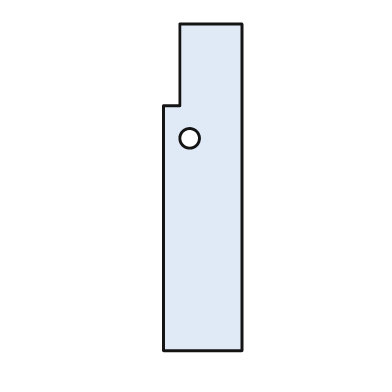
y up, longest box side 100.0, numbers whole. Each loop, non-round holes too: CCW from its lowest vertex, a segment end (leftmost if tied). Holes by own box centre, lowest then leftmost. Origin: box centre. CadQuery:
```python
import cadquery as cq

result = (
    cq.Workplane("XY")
    .moveTo(-12.0, -50.0)
    .lineTo(12.0, -50.0)
    .lineTo(12.0, 50.0)
    .lineTo(-7.0, 50.0)
    .lineTo(-7.0, 25.0)
    .lineTo(-12.0, 25.0)
    .close()
    .moveTo(-4.0, 15.0)
    .circle(3.0)
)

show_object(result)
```